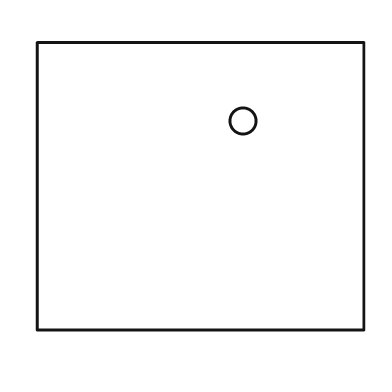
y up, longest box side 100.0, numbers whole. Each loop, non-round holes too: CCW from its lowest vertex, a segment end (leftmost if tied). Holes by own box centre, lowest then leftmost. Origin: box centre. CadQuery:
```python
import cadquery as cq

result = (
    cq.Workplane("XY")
    .moveTo(-50.0, -44.0)
    .lineTo(50.0, -44.0)
    .lineTo(50.0, 44.0)
    .lineTo(-50.0, 44.0)
    .close()
    .moveTo(13.0, 20.0)
    .circle(4.0)
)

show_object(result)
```